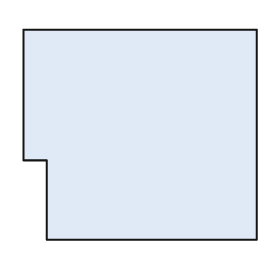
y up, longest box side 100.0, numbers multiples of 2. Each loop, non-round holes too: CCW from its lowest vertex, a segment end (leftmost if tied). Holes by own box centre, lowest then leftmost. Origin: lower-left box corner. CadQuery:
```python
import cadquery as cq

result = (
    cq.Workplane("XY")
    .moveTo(10.0, 0.0)
    .lineTo(100.0, 0.0)
    .lineTo(100.0, 90.0)
    .lineTo(0.0, 90.0)
    .lineTo(0.0, 34.0)
    .lineTo(10.0, 34.0)
    .close()
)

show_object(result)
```